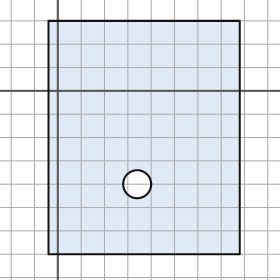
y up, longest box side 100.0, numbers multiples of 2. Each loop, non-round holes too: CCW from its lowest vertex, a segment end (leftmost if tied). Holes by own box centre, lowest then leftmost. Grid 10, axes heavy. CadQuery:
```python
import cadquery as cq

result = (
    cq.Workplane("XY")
    .moveTo(-4.0, -70.0)
    .lineTo(78.0, -70.0)
    .lineTo(78.0, 30.0)
    .lineTo(-4.0, 30.0)
    .close()
    .moveTo(34.0, -40.0)
    .circle(6.0)
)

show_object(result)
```